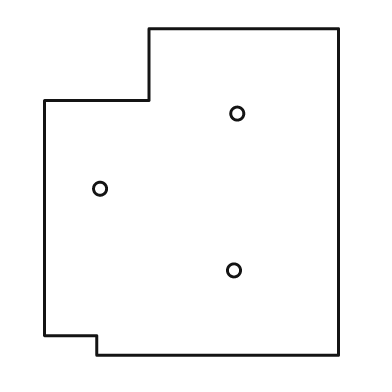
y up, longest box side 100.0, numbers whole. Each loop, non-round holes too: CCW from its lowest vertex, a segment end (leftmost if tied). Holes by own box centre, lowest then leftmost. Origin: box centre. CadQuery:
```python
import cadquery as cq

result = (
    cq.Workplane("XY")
    .moveTo(-29.0, -50.0)
    .lineTo(45.0, -50.0)
    .lineTo(45.0, 50.0)
    .lineTo(-13.0, 50.0)
    .lineTo(-13.0, 28.0)
    .lineTo(-45.0, 28.0)
    .lineTo(-45.0, -44.0)
    .lineTo(-29.0, -44.0)
    .close()
    .moveTo(13.0, -24.0)
    .circle(2.0)
    .moveTo(-28.0, 1.0)
    .circle(2.0)
    .moveTo(14.0, 24.0)
    .circle(2.0)
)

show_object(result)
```